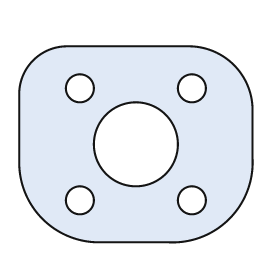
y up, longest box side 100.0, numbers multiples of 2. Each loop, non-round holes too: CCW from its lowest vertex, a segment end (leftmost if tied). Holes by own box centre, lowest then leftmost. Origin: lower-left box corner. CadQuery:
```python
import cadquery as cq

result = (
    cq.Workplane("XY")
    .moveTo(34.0, 0.0)
    .lineTo(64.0, 0.0)
    .threePointArc((90.0, 10.0), (100.0, 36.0))
    .lineTo(100.0, 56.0)
    .threePointArc((92.0, 76.0), (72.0, 84.0))
    .lineTo(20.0, 84.0)
    .threePointArc((6.0, 78.0), (0.0, 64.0))
    .lineTo(0.0, 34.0)
    .threePointArc((10.0, 10.0), (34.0, 0.0))
    .close()
    .moveTo(26.0, 18.0)
    .circle(6.0)
    .moveTo(74.0, 18.0)
    .circle(6.0)
    .moveTo(50.0, 42.0)
    .circle(18.0)
    .moveTo(26.0, 66.0)
    .circle(6.0)
    .moveTo(74.0, 66.0)
    .circle(6.0)
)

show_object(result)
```